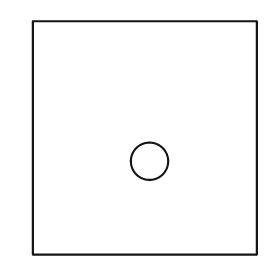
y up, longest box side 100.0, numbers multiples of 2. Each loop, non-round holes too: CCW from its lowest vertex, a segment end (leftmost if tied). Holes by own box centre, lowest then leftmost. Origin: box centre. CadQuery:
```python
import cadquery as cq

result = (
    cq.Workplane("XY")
    .moveTo(-48.0, -50.0)
    .lineTo(48.0, -50.0)
    .lineTo(48.0, 50.0)
    .lineTo(-48.0, 50.0)
    .close()
    .moveTo(2.0, -10.0)
    .circle(8.0)
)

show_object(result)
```